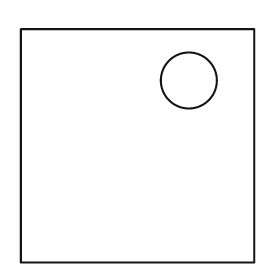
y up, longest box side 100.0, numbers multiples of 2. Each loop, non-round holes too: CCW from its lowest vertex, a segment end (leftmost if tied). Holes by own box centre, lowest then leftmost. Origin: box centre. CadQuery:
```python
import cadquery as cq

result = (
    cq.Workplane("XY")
    .moveTo(-50.0, -50.0)
    .lineTo(50.0, -50.0)
    .lineTo(50.0, 50.0)
    .lineTo(-50.0, 50.0)
    .close()
    .moveTo(22.0, 28.0)
    .circle(12.0)
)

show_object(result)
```